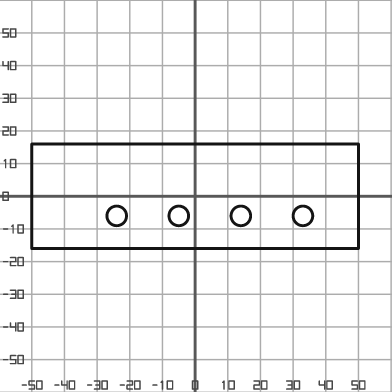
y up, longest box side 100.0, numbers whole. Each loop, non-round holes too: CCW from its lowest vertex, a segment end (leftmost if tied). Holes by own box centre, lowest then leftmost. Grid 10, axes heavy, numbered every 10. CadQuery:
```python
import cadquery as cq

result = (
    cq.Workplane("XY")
    .moveTo(-50.0, -16.0)
    .lineTo(50.0, -16.0)
    .lineTo(50.0, 16.0)
    .lineTo(-50.0, 16.0)
    .close()
    .moveTo(-24.0, -6.0)
    .circle(3.0)
    .moveTo(-5.0, -6.0)
    .circle(3.0)
    .moveTo(14.0, -6.0)
    .circle(3.0)
    .moveTo(33.0, -6.0)
    .circle(3.0)
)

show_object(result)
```